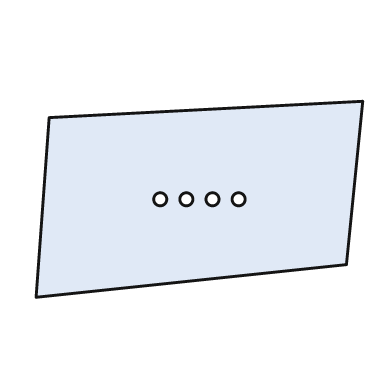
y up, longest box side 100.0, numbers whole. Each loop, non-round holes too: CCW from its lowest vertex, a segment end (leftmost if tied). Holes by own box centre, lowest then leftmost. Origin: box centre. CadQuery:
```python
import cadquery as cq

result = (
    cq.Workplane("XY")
    .moveTo(-50.0, -30.0)
    .lineTo(45.0, -20.0)
    .lineTo(50.0, 30.0)
    .lineTo(-46.0, 25.0)
    .close()
    .moveTo(-12.0, 0.0)
    .circle(2.0)
    .moveTo(-4.0, 0.0)
    .circle(2.0)
    .moveTo(4.0, 0.0)
    .circle(2.0)
    .moveTo(12.0, 0.0)
    .circle(2.0)
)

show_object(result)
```